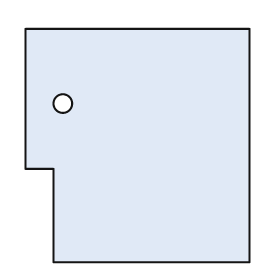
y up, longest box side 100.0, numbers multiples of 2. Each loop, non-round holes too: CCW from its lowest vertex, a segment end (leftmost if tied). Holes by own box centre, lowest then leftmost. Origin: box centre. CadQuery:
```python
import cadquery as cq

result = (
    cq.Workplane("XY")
    .moveTo(-36.0, -50.0)
    .lineTo(48.0, -50.0)
    .lineTo(48.0, 50.0)
    .lineTo(-48.0, 50.0)
    .lineTo(-48.0, -10.0)
    .lineTo(-36.0, -10.0)
    .close()
    .moveTo(-32.0, 18.0)
    .circle(4.0)
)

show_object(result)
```